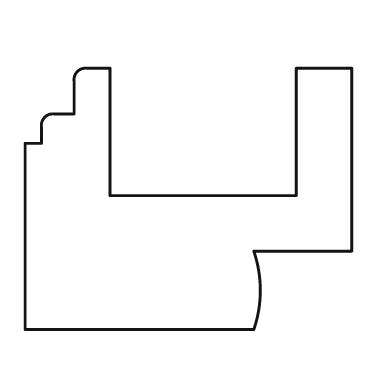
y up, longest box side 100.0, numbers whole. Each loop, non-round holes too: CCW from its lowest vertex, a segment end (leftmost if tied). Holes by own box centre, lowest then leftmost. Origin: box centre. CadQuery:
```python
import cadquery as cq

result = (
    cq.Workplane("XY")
    .moveTo(-50.0, -40.0)
    .lineTo(20.0, -40.0)
    .threePointArc((22.0, -28.0), (20.0, -16.0))
    .lineTo(50.0, -16.0)
    .lineTo(50.0, 40.0)
    .lineTo(33.0, 40.0)
    .lineTo(33.0, 1.0)
    .lineTo(-24.0, 1.0)
    .lineTo(-24.0, 40.0)
    .lineTo(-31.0, 40.0)
    .threePointArc((-34.0, 39.0), (-35.0, 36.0))
    .lineTo(-35.0, 26.0)
    .lineTo(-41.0, 26.0)
    .threePointArc((-44.0, 25.0), (-45.0, 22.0))
    .lineTo(-45.0, 17.0)
    .lineTo(-50.0, 17.0)
    .close()
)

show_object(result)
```